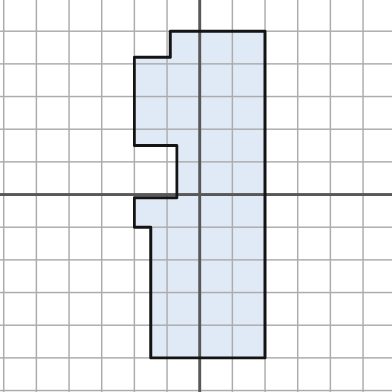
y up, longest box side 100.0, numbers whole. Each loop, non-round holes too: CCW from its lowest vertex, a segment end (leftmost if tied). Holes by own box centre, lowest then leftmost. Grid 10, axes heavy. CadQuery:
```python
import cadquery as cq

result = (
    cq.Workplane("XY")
    .moveTo(-15.0, -50.0)
    .lineTo(20.0, -50.0)
    .lineTo(20.0, 50.0)
    .lineTo(-9.0, 50.0)
    .lineTo(-9.0, 42.0)
    .lineTo(-20.0, 42.0)
    .lineTo(-20.0, 15.0)
    .lineTo(-7.0, 15.0)
    .lineTo(-7.0, -1.0)
    .lineTo(-20.0, -1.0)
    .lineTo(-20.0, -10.0)
    .lineTo(-15.0, -10.0)
    .close()
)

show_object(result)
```